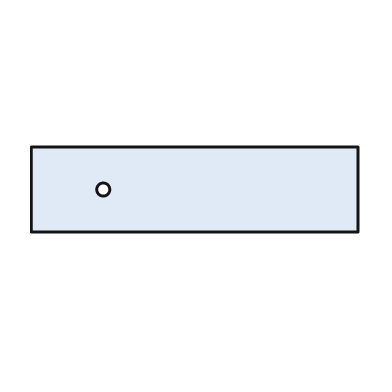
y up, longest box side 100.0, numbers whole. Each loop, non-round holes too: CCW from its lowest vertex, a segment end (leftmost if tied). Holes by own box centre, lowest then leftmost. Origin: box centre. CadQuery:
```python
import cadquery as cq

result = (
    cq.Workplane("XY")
    .moveTo(-50.0, -13.0)
    .lineTo(50.0, -13.0)
    .lineTo(50.0, 13.0)
    .lineTo(-50.0, 13.0)
    .close()
    .moveTo(-28.0, 0.0)
    .circle(2.0)
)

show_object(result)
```